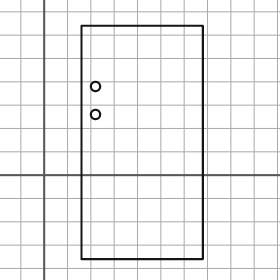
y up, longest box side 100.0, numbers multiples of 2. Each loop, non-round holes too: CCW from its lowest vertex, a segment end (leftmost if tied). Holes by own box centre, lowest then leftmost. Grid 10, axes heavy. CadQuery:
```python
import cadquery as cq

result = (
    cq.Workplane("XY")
    .moveTo(16.0, -36.0)
    .lineTo(68.0, -36.0)
    .lineTo(68.0, 64.0)
    .lineTo(16.0, 64.0)
    .close()
    .moveTo(22.0, 26.0)
    .circle(2.0)
    .moveTo(22.0, 38.0)
    .circle(2.0)
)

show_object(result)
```